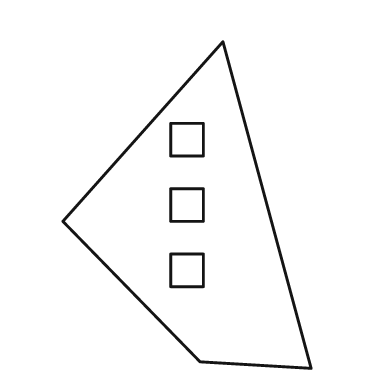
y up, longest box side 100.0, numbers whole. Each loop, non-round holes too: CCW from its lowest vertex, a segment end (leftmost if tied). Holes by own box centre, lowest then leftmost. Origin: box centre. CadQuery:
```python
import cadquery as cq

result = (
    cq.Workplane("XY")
    .moveTo(38.0, -50.0)
    .lineTo(11.0, 50.0)
    .lineTo(-38.0, -5.0)
    .lineTo(4.0, -48.0)
    .close()
    .moveTo(-5.0, -25.0)
    .lineTo(5.0, -25.0)
    .lineTo(5.0, -15.0)
    .lineTo(-5.0, -15.0)
    .close()
    .moveTo(-5.0, -5.0)
    .lineTo(5.0, -5.0)
    .lineTo(5.0, 5.0)
    .lineTo(-5.0, 5.0)
    .close()
    .moveTo(-5.0, 15.0)
    .lineTo(5.0, 15.0)
    .lineTo(5.0, 25.0)
    .lineTo(-5.0, 25.0)
    .close()
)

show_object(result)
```